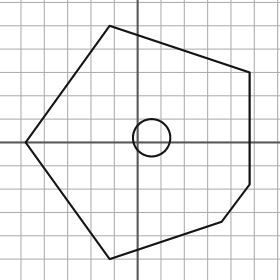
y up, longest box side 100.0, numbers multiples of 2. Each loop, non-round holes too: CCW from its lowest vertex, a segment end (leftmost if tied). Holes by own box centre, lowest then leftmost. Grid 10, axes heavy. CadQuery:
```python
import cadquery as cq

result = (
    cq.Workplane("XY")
    .moveTo(-12.0, -50.0)
    .lineTo(36.0, -34.0)
    .lineTo(48.0, -18.0)
    .lineTo(48.0, 30.0)
    .lineTo(-12.0, 50.0)
    .lineTo(-48.0, 0.0)
    .close()
    .moveTo(6.0, 2.0)
    .circle(8.0)
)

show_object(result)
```